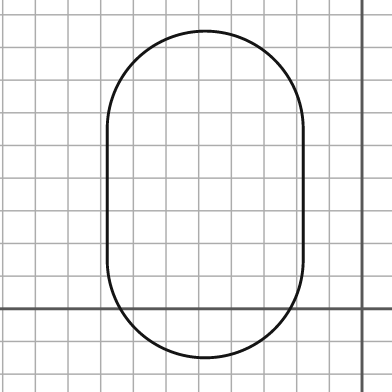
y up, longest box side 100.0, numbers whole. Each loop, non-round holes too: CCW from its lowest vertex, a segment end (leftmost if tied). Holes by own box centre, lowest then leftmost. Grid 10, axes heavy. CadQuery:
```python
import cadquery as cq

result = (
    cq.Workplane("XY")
    .moveTo(-78.0, 15.0)
    .threePointArc((-48.0, -15.0), (-18.0, 15.0))
    .lineTo(-18.0, 55.0)
    .threePointArc((-48.0, 85.0), (-78.0, 55.0))
    .close()
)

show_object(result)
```